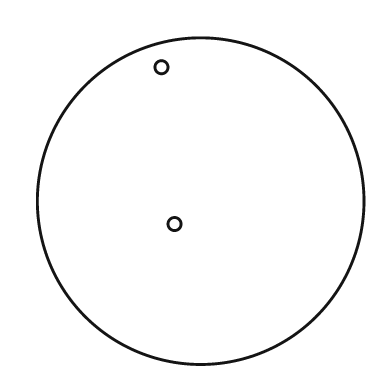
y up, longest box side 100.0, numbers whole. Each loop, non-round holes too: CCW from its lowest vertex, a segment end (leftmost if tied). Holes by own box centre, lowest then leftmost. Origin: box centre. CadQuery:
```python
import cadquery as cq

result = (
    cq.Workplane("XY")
    .moveTo(0.0, 0.0)
    .circle(50.0)
    .moveTo(-8.0, -7.0)
    .circle(2.0)
    .moveTo(-12.0, 41.0)
    .circle(2.0)
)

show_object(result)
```